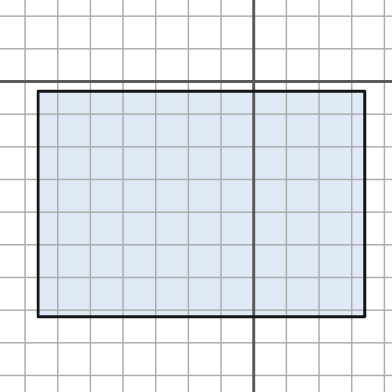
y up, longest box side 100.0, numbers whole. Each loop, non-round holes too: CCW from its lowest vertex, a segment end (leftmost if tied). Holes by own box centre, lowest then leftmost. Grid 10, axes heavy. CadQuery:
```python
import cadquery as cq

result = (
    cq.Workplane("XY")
    .moveTo(-66.0, -72.0)
    .lineTo(34.0, -72.0)
    .lineTo(34.0, -3.0)
    .lineTo(-66.0, -3.0)
    .close()
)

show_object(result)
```